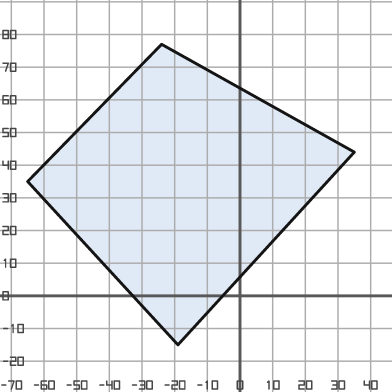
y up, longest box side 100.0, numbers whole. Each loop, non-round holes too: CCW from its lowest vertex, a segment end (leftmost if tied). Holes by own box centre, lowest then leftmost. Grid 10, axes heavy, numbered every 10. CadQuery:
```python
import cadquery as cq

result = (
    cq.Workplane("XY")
    .moveTo(-19.0, -15.0)
    .lineTo(35.0, 44.0)
    .lineTo(-24.0, 77.0)
    .lineTo(-65.0, 35.0)
    .close()
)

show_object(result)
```